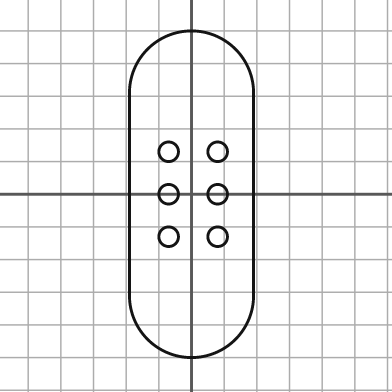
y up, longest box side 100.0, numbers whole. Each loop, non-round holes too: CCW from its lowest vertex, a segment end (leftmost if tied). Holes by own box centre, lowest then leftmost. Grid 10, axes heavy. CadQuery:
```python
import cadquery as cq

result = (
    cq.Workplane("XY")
    .moveTo(-19.0, -31.0)
    .threePointArc((0.0, -50.0), (19.0, -31.0))
    .lineTo(19.0, 31.0)
    .threePointArc((0.0, 50.0), (-19.0, 31.0))
    .close()
    .moveTo(-7.0, -13.0)
    .circle(3.0)
    .moveTo(8.0, -13.0)
    .circle(3.0)
    .moveTo(-7.0, 0.0)
    .circle(3.0)
    .moveTo(8.0, 0.0)
    .circle(3.0)
    .moveTo(-7.0, 13.0)
    .circle(3.0)
    .moveTo(8.0, 13.0)
    .circle(3.0)
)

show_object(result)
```